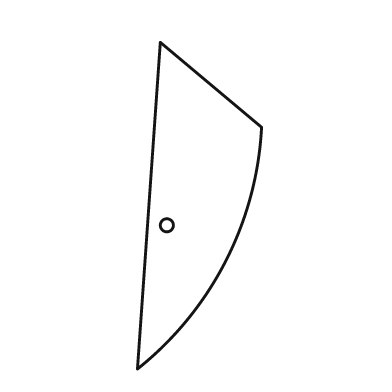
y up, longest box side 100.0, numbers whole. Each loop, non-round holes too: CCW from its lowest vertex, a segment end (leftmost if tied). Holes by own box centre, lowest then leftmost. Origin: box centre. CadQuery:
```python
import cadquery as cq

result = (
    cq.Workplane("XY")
    .moveTo(-19.0, -50.0)
    .threePointArc((8.0, -17.0), (19.0, 24.0))
    .lineTo(-12.0, 50.0)
    .close()
    .moveTo(-10.0, -6.0)
    .circle(2.0)
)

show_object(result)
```